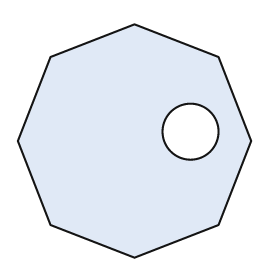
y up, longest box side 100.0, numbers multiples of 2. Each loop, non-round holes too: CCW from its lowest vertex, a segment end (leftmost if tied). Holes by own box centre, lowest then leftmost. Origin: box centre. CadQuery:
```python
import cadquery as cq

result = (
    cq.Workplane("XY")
    .moveTo(0.0, -50.0)
    .lineTo(36.0, -36.0)
    .lineTo(50.0, 0.0)
    .lineTo(36.0, 36.0)
    .lineTo(0.0, 50.0)
    .lineTo(-36.0, 36.0)
    .lineTo(-50.0, 0.0)
    .lineTo(-36.0, -36.0)
    .close()
    .moveTo(24.0, 4.0)
    .circle(12.0)
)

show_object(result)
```